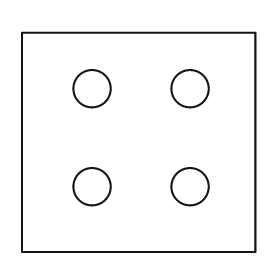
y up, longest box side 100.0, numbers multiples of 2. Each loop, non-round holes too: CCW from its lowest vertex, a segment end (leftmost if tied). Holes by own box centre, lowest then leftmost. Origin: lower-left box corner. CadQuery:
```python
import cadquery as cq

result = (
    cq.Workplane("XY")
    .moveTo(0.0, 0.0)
    .lineTo(100.0, 0.0)
    .lineTo(100.0, 94.0)
    .lineTo(0.0, 94.0)
    .close()
    .moveTo(30.0, 28.0)
    .circle(8.0)
    .moveTo(72.0, 28.0)
    .circle(8.0)
    .moveTo(30.0, 70.0)
    .circle(8.0)
    .moveTo(72.0, 70.0)
    .circle(8.0)
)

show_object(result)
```